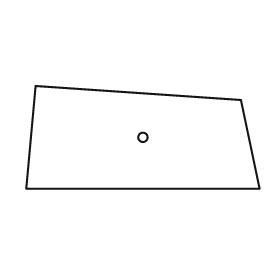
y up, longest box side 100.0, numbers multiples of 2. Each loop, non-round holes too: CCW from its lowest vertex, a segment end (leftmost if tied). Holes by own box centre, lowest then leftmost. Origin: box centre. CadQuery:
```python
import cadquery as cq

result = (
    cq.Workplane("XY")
    .moveTo(-50.0, -22.0)
    .lineTo(50.0, -22.0)
    .lineTo(42.0, 16.0)
    .lineTo(-46.0, 22.0)
    .close()
    .moveTo(0.0, 0.0)
    .circle(2.0)
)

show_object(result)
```